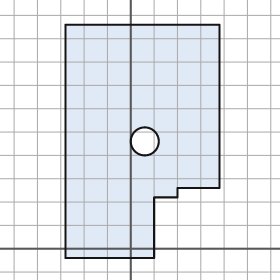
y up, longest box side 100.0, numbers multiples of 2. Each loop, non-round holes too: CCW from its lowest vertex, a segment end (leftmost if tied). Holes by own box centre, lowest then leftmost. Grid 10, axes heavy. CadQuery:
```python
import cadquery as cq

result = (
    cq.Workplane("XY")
    .moveTo(-28.0, -4.0)
    .lineTo(10.0, -4.0)
    .lineTo(10.0, 22.0)
    .lineTo(20.0, 22.0)
    .lineTo(20.0, 26.0)
    .lineTo(38.0, 26.0)
    .lineTo(38.0, 96.0)
    .lineTo(-28.0, 96.0)
    .close()
    .moveTo(6.0, 46.0)
    .circle(6.0)
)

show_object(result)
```